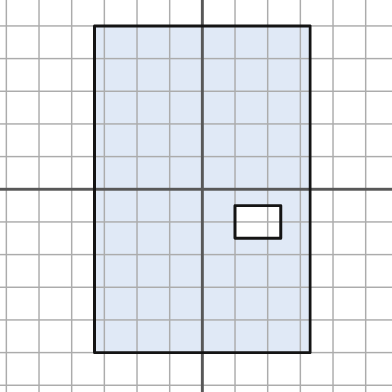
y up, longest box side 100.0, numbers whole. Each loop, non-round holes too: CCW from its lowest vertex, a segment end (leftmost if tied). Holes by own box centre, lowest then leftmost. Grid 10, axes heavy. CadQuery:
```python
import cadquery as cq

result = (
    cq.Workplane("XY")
    .moveTo(-33.0, -50.0)
    .lineTo(33.0, -50.0)
    .lineTo(33.0, 50.0)
    .lineTo(-33.0, 50.0)
    .close()
    .moveTo(10.0, -15.0)
    .lineTo(24.0, -15.0)
    .lineTo(24.0, -5.0)
    .lineTo(10.0, -5.0)
    .close()
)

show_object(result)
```